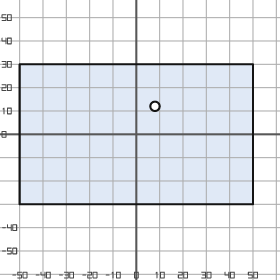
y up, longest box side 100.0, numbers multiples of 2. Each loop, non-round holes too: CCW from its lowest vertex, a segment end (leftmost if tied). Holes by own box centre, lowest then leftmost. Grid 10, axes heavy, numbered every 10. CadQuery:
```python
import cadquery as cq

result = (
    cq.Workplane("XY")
    .moveTo(-50.0, -30.0)
    .lineTo(50.0, -30.0)
    .lineTo(50.0, 30.0)
    .lineTo(-50.0, 30.0)
    .close()
    .moveTo(8.0, 12.0)
    .circle(2.0)
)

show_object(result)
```